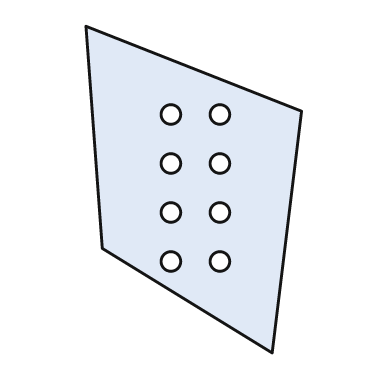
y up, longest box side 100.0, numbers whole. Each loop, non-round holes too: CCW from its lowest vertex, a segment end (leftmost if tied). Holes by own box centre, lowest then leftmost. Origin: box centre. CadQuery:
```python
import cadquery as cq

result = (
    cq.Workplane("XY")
    .moveTo(24.0, -50.0)
    .lineTo(33.0, 24.0)
    .lineTo(-33.0, 50.0)
    .lineTo(-28.0, -18.0)
    .close()
    .moveTo(-7.0, -22.0)
    .circle(3.0)
    .moveTo(8.0, -22.0)
    .circle(3.0)
    .moveTo(-7.0, -7.0)
    .circle(3.0)
    .moveTo(8.0, -7.0)
    .circle(3.0)
    .moveTo(-7.0, 8.0)
    .circle(3.0)
    .moveTo(8.0, 8.0)
    .circle(3.0)
    .moveTo(-7.0, 23.0)
    .circle(3.0)
    .moveTo(8.0, 23.0)
    .circle(3.0)
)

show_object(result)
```